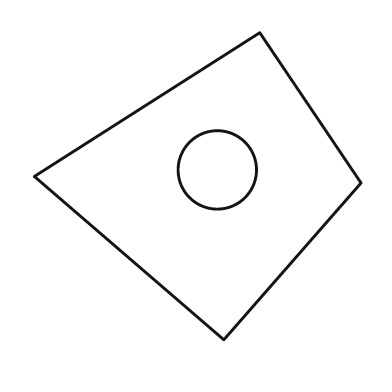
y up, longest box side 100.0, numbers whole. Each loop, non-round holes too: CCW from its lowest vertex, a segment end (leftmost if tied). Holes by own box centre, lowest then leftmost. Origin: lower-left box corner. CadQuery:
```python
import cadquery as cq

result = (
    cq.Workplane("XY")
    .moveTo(58.0, 0.0)
    .lineTo(100.0, 48.0)
    .lineTo(69.0, 94.0)
    .lineTo(0.0, 50.0)
    .close()
    .moveTo(56.0, 52.0)
    .circle(12.0)
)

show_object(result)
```